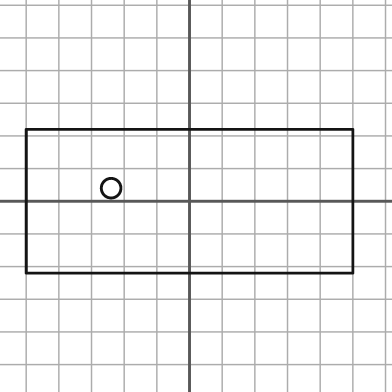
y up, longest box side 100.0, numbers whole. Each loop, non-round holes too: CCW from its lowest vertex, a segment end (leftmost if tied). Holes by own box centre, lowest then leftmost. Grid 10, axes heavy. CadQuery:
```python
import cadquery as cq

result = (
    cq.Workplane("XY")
    .moveTo(-50.0, -22.0)
    .lineTo(50.0, -22.0)
    .lineTo(50.0, 22.0)
    .lineTo(-50.0, 22.0)
    .close()
    .moveTo(-24.0, 4.0)
    .circle(3.0)
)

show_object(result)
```